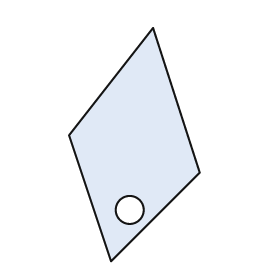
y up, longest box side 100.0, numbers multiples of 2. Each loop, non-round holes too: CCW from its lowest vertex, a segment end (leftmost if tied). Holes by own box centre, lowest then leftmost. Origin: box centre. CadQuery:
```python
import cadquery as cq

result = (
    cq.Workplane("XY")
    .moveTo(-10.0, -50.0)
    .lineTo(28.0, -12.0)
    .lineTo(8.0, 50.0)
    .lineTo(-28.0, 4.0)
    .close()
    .moveTo(-2.0, -28.0)
    .circle(6.0)
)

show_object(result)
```